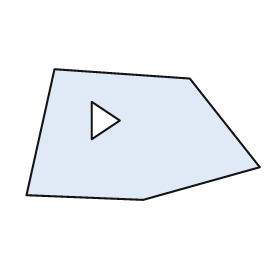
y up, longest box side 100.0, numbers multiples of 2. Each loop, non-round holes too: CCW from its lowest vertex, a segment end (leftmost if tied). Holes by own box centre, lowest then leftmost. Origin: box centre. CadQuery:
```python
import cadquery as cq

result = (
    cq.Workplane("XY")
    .moveTo(0.0, -28.0)
    .lineTo(50.0, -14.0)
    .lineTo(20.0, 24.0)
    .lineTo(-38.0, 28.0)
    .lineTo(-50.0, -26.0)
    .close()
    .moveTo(-22.0, -2.0)
    .lineTo(-10.0, 6.0)
    .lineTo(-22.0, 14.0)
    .close()
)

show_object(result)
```